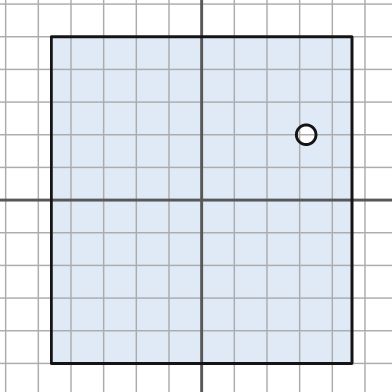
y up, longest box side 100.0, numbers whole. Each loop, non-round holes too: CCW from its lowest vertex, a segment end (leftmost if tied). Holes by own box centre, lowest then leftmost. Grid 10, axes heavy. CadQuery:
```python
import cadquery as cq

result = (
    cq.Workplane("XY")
    .moveTo(-46.0, -50.0)
    .lineTo(46.0, -50.0)
    .lineTo(46.0, 50.0)
    .lineTo(-46.0, 50.0)
    .close()
    .moveTo(32.0, 20.0)
    .circle(3.0)
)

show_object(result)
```